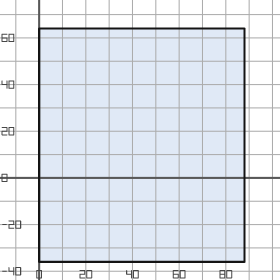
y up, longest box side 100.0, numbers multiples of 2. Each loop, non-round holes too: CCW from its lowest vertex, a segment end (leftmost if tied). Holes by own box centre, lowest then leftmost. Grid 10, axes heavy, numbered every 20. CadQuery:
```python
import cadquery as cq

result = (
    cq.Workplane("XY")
    .moveTo(0.0, -36.0)
    .lineTo(88.0, -36.0)
    .lineTo(88.0, 64.0)
    .lineTo(0.0, 64.0)
    .close()
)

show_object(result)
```